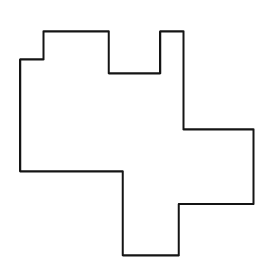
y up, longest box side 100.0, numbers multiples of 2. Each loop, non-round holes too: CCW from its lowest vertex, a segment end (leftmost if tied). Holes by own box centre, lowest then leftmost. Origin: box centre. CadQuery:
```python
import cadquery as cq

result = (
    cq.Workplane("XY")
    .moveTo(-6.0, -48.0)
    .lineTo(18.0, -48.0)
    .lineTo(18.0, -26.0)
    .lineTo(50.0, -26.0)
    .lineTo(50.0, 6.0)
    .lineTo(20.0, 6.0)
    .lineTo(20.0, 48.0)
    .lineTo(10.0, 48.0)
    .lineTo(10.0, 30.0)
    .lineTo(-12.0, 30.0)
    .lineTo(-12.0, 48.0)
    .lineTo(-40.0, 48.0)
    .lineTo(-40.0, 36.0)
    .lineTo(-50.0, 36.0)
    .lineTo(-50.0, -12.0)
    .lineTo(-6.0, -12.0)
    .close()
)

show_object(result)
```